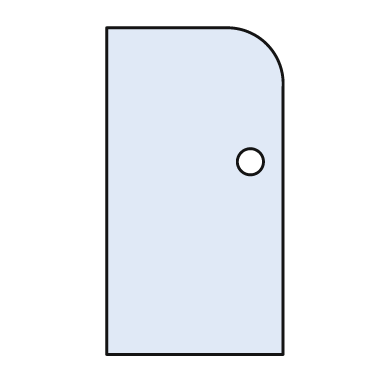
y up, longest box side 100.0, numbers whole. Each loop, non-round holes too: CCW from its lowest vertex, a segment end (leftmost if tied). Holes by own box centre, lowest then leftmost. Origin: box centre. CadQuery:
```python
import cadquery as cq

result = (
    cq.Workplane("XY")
    .moveTo(-27.0, -50.0)
    .lineTo(27.0, -50.0)
    .lineTo(27.0, 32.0)
    .threePointArc((22.0, 45.0), (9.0, 50.0))
    .lineTo(-27.0, 50.0)
    .close()
    .moveTo(17.0, 9.0)
    .circle(4.0)
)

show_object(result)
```